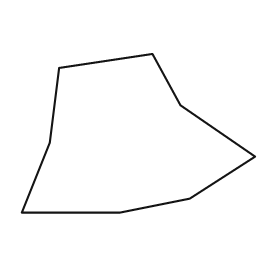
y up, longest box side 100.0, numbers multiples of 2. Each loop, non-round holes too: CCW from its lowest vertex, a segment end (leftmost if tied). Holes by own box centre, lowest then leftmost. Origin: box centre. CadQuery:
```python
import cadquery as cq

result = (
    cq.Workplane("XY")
    .moveTo(-50.0, -34.0)
    .lineTo(-8.0, -34.0)
    .lineTo(22.0, -28.0)
    .lineTo(50.0, -10.0)
    .lineTo(18.0, 12.0)
    .lineTo(6.0, 34.0)
    .lineTo(-34.0, 28.0)
    .lineTo(-38.0, -4.0)
    .close()
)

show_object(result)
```